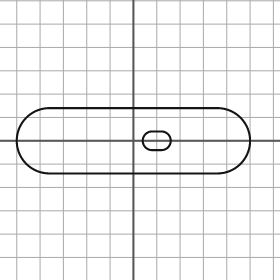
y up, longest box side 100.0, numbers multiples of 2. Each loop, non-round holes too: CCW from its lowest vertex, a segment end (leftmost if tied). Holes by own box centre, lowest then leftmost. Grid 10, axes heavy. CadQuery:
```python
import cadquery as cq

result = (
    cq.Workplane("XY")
    .moveTo(-36.0, -14.0)
    .lineTo(36.0, -14.0)
    .threePointArc((50.0, 0.0), (36.0, 14.0))
    .lineTo(-36.0, 14.0)
    .threePointArc((-50.0, 0.0), (-36.0, -14.0))
    .close()
    .moveTo(8.0, -4.0)
    .lineTo(12.0, -4.0)
    .threePointArc((16.0, 0.0), (12.0, 4.0))
    .lineTo(8.0, 4.0)
    .threePointArc((4.0, 0.0), (8.0, -4.0))
    .close()
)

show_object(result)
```